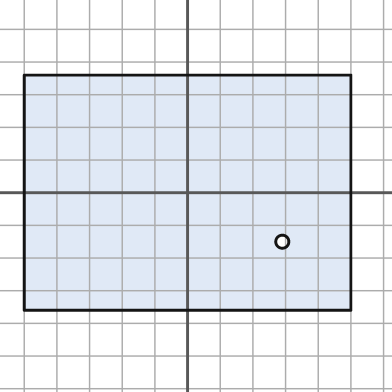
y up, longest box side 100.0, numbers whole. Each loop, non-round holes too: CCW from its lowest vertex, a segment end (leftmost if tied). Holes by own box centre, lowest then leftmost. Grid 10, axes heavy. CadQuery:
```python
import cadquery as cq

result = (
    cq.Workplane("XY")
    .moveTo(-50.0, -36.0)
    .lineTo(50.0, -36.0)
    .lineTo(50.0, 36.0)
    .lineTo(-50.0, 36.0)
    .close()
    .moveTo(29.0, -15.0)
    .circle(2.0)
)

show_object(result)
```